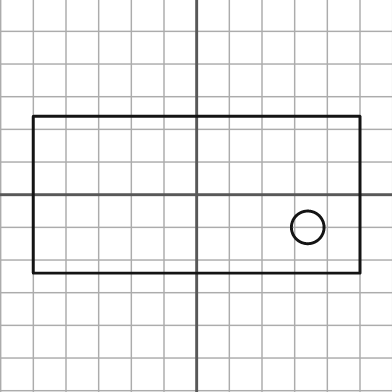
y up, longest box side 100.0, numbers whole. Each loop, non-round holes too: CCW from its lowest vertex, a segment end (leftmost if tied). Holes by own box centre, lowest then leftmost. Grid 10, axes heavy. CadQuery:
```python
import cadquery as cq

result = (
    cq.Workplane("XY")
    .moveTo(-50.0, -24.0)
    .lineTo(50.0, -24.0)
    .lineTo(50.0, 24.0)
    .lineTo(-50.0, 24.0)
    .close()
    .moveTo(34.0, -10.0)
    .circle(5.0)
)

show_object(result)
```